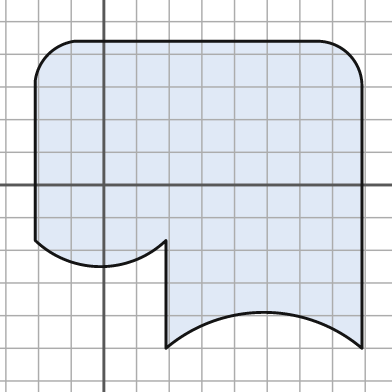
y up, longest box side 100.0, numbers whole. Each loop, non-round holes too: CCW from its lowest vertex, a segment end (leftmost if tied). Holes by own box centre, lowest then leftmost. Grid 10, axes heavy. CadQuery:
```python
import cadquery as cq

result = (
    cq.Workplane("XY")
    .moveTo(19.0, -50.0)
    .threePointArc((49.0, -39.0), (79.0, -50.0))
    .lineTo(79.0, 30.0)
    .threePointArc((75.0, 40.0), (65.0, 44.0))
    .lineTo(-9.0, 44.0)
    .threePointArc((-17.0, 40.0), (-21.0, 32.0))
    .lineTo(-21.0, -17.0)
    .threePointArc((-1.0, -25.0), (19.0, -17.0))
    .close()
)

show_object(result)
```